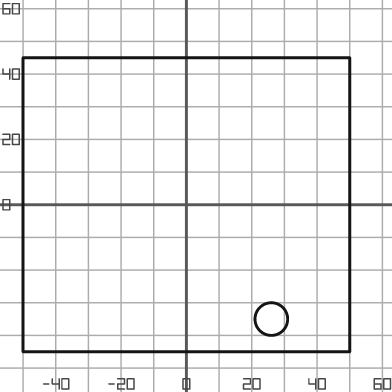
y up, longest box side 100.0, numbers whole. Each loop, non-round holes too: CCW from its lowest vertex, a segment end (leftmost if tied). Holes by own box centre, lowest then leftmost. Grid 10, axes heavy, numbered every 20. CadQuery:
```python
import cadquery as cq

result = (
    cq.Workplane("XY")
    .moveTo(-50.0, -45.0)
    .lineTo(50.0, -45.0)
    .lineTo(50.0, 45.0)
    .lineTo(-50.0, 45.0)
    .close()
    .moveTo(26.0, -35.0)
    .circle(5.0)
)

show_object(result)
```